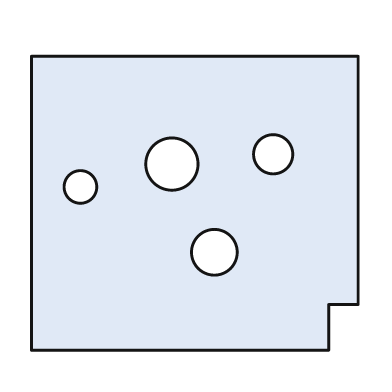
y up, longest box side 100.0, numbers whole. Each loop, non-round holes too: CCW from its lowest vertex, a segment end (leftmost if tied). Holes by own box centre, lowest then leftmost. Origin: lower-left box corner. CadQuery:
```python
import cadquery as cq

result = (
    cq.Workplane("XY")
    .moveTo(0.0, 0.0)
    .lineTo(91.0, 0.0)
    .lineTo(91.0, 14.0)
    .lineTo(100.0, 14.0)
    .lineTo(100.0, 90.0)
    .lineTo(0.0, 90.0)
    .close()
    .moveTo(56.0, 30.0)
    .circle(7.0)
    .moveTo(15.0, 50.0)
    .circle(5.0)
    .moveTo(43.0, 57.0)
    .circle(8.0)
    .moveTo(74.0, 60.0)
    .circle(6.0)
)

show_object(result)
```